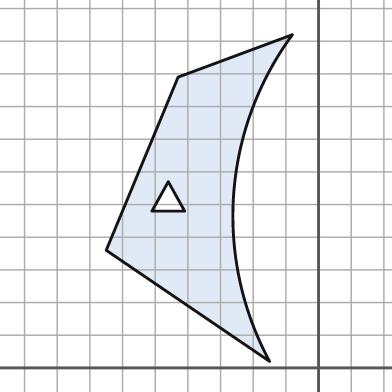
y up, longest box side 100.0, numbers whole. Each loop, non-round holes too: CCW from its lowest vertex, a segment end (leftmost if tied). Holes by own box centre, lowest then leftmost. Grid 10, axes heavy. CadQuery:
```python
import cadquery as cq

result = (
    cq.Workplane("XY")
    .moveTo(-15.0, 2.0)
    .threePointArc((-26.0, 53.0), (-8.0, 102.0))
    .lineTo(-43.0, 89.0)
    .lineTo(-65.0, 36.0)
    .close()
    .moveTo(-51.0, 48.0)
    .lineTo(-41.0, 48.0)
    .lineTo(-46.0, 57.0)
    .close()
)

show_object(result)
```